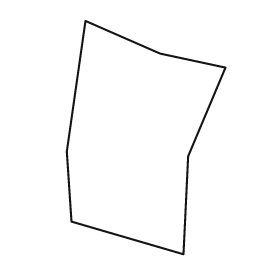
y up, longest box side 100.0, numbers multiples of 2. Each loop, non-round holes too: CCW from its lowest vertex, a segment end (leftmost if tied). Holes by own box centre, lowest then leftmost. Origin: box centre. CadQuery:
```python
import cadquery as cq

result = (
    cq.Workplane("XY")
    .moveTo(16.0, -50.0)
    .lineTo(18.0, -8.0)
    .lineTo(34.0, 30.0)
    .lineTo(6.0, 36.0)
    .lineTo(-26.0, 50.0)
    .lineTo(-34.0, -6.0)
    .lineTo(-32.0, -36.0)
    .close()
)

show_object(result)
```